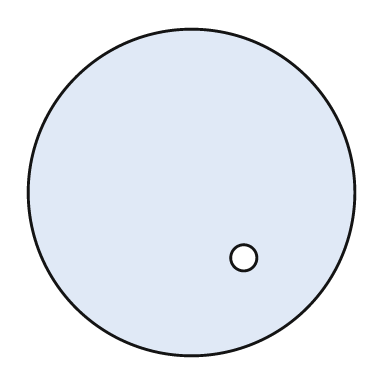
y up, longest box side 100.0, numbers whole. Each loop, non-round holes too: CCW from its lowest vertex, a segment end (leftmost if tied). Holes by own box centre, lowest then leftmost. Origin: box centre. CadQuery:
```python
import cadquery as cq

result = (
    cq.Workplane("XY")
    .moveTo(0.0, 0.0)
    .circle(50.0)
    .moveTo(16.0, -20.0)
    .circle(4.0)
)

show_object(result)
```